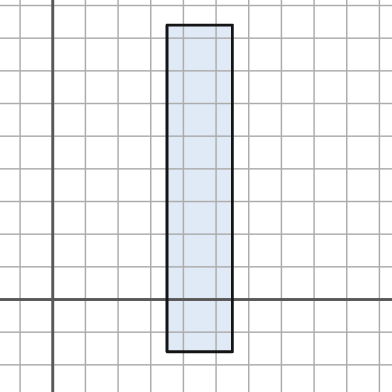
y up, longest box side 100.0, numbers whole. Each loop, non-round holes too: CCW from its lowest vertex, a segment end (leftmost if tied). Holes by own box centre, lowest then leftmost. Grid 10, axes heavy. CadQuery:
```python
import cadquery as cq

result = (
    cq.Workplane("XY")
    .moveTo(35.0, -16.0)
    .lineTo(55.0, -16.0)
    .lineTo(55.0, 84.0)
    .lineTo(35.0, 84.0)
    .close()
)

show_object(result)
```